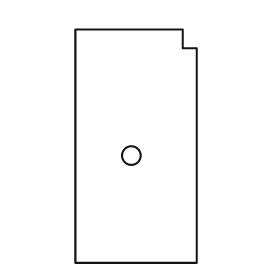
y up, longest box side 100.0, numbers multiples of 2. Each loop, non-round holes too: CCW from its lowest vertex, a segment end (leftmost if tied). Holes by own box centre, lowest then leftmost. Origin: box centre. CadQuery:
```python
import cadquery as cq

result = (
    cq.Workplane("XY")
    .moveTo(-26.0, -50.0)
    .lineTo(26.0, -50.0)
    .lineTo(26.0, 42.0)
    .lineTo(20.0, 42.0)
    .lineTo(20.0, 50.0)
    .lineTo(-26.0, 50.0)
    .close()
    .moveTo(-2.0, -4.0)
    .circle(4.0)
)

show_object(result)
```